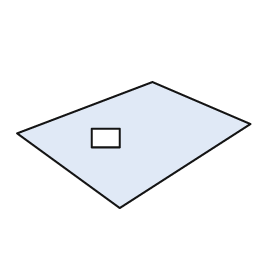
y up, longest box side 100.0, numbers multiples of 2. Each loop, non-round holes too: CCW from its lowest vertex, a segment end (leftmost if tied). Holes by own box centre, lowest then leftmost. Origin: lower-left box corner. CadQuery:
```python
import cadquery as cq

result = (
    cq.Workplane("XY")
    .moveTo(44.0, 0.0)
    .lineTo(100.0, 36.0)
    .lineTo(58.0, 54.0)
    .lineTo(0.0, 32.0)
    .close()
    .moveTo(32.0, 26.0)
    .lineTo(44.0, 26.0)
    .lineTo(44.0, 34.0)
    .lineTo(32.0, 34.0)
    .close()
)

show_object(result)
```